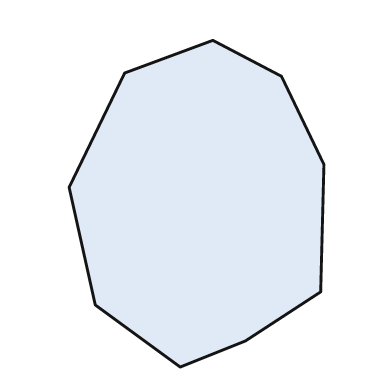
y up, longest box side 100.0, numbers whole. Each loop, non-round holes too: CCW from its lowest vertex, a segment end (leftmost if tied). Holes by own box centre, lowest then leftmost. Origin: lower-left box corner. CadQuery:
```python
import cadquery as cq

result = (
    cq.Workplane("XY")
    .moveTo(34.0, 0.0)
    .lineTo(54.0, 8.0)
    .lineTo(77.0, 23.0)
    .lineTo(78.0, 62.0)
    .lineTo(65.0, 89.0)
    .lineTo(44.0, 100.0)
    .lineTo(17.0, 90.0)
    .lineTo(0.0, 55.0)
    .lineTo(8.0, 19.0)
    .close()
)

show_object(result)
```